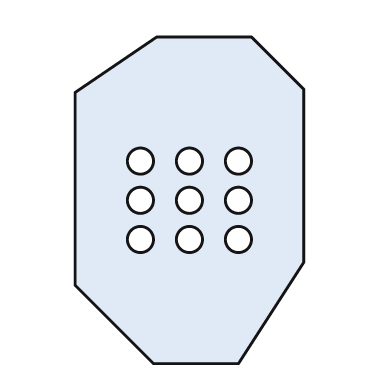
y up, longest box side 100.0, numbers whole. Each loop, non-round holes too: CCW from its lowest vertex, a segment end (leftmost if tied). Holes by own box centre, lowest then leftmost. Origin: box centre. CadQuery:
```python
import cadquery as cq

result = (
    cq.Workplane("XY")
    .moveTo(-11.0, -50.0)
    .lineTo(15.0, -50.0)
    .lineTo(35.0, -19.0)
    .lineTo(35.0, 34.0)
    .lineTo(19.0, 50.0)
    .lineTo(-10.0, 50.0)
    .lineTo(-35.0, 33.0)
    .lineTo(-35.0, -26.0)
    .close()
    .moveTo(-15.0, -12.0)
    .circle(4.0)
    .moveTo(0.0, -12.0)
    .circle(4.0)
    .moveTo(15.0, -12.0)
    .circle(4.0)
    .moveTo(-15.0, 0.0)
    .circle(4.0)
    .moveTo(0.0, 0.0)
    .circle(4.0)
    .moveTo(15.0, 0.0)
    .circle(4.0)
    .moveTo(-15.0, 12.0)
    .circle(4.0)
    .moveTo(0.0, 12.0)
    .circle(4.0)
    .moveTo(15.0, 12.0)
    .circle(4.0)
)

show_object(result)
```